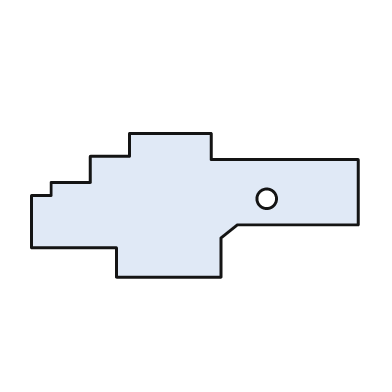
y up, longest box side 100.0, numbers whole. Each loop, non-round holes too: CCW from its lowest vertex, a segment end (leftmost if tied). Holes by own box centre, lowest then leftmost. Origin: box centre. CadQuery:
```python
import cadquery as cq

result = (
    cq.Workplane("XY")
    .moveTo(-24.0, -22.0)
    .lineTo(8.0, -22.0)
    .lineTo(8.0, -10.0)
    .lineTo(13.0, -6.0)
    .lineTo(50.0, -6.0)
    .lineTo(50.0, 14.0)
    .lineTo(5.0, 14.0)
    .lineTo(5.0, 22.0)
    .lineTo(-20.0, 22.0)
    .lineTo(-20.0, 15.0)
    .lineTo(-32.0, 15.0)
    .lineTo(-32.0, 7.0)
    .lineTo(-44.0, 7.0)
    .lineTo(-44.0, 3.0)
    .lineTo(-50.0, 3.0)
    .lineTo(-50.0, -13.0)
    .lineTo(-24.0, -13.0)
    .close()
    .moveTo(22.0, 2.0)
    .circle(3.0)
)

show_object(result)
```